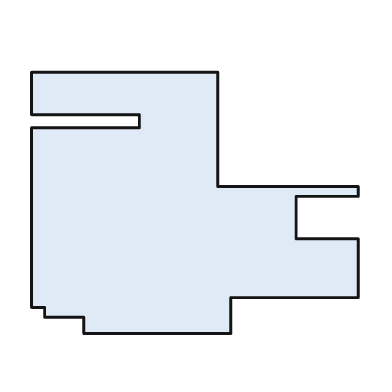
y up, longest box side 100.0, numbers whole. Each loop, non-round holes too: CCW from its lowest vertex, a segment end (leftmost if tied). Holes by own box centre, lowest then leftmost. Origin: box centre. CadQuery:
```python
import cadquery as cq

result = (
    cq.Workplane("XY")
    .moveTo(-34.0, -40.0)
    .lineTo(11.0, -40.0)
    .lineTo(11.0, -29.0)
    .lineTo(50.0, -29.0)
    .lineTo(50.0, -11.0)
    .lineTo(31.0, -11.0)
    .lineTo(31.0, 2.0)
    .lineTo(50.0, 2.0)
    .lineTo(50.0, 5.0)
    .lineTo(7.0, 5.0)
    .lineTo(7.0, 40.0)
    .lineTo(-50.0, 40.0)
    .lineTo(-50.0, 27.0)
    .lineTo(-17.0, 27.0)
    .lineTo(-17.0, 23.0)
    .lineTo(-50.0, 23.0)
    .lineTo(-50.0, -32.0)
    .lineTo(-46.0, -32.0)
    .lineTo(-46.0, -35.0)
    .lineTo(-34.0, -35.0)
    .close()
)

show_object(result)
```